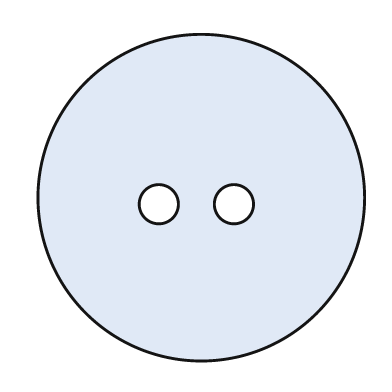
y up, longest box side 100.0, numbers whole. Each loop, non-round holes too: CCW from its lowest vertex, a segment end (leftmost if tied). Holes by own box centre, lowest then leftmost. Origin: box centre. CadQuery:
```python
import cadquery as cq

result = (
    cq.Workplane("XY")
    .moveTo(0.0, 0.0)
    .circle(50.0)
    .moveTo(-13.0, -2.0)
    .circle(6.0)
    .moveTo(10.0, -2.0)
    .circle(6.0)
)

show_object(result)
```